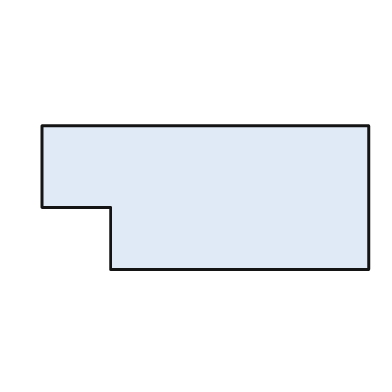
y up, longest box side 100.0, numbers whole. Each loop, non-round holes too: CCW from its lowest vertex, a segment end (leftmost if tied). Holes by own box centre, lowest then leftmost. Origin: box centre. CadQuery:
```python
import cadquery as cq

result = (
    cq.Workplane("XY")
    .moveTo(-29.0, -22.0)
    .lineTo(50.0, -22.0)
    .lineTo(50.0, 22.0)
    .lineTo(-50.0, 22.0)
    .lineTo(-50.0, -3.0)
    .lineTo(-29.0, -3.0)
    .close()
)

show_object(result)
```